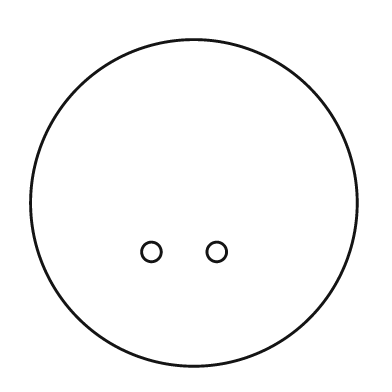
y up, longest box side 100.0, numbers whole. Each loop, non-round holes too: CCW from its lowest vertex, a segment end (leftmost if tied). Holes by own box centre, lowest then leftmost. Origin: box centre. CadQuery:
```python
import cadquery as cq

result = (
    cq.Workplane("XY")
    .moveTo(0.0, 0.0)
    .circle(50.0)
    .moveTo(-13.0, -15.0)
    .circle(3.0)
    .moveTo(7.0, -15.0)
    .circle(3.0)
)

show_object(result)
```